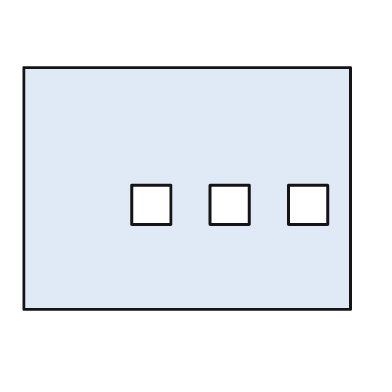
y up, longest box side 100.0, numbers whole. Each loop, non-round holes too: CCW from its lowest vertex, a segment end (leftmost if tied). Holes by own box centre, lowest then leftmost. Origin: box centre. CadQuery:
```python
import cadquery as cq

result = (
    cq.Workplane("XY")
    .moveTo(-50.0, -37.0)
    .lineTo(50.0, -37.0)
    .lineTo(50.0, 37.0)
    .lineTo(-50.0, 37.0)
    .close()
    .moveTo(-17.0, -11.0)
    .lineTo(-5.0, -11.0)
    .lineTo(-5.0, 1.0)
    .lineTo(-17.0, 1.0)
    .close()
    .moveTo(7.0, -11.0)
    .lineTo(19.0, -11.0)
    .lineTo(19.0, 1.0)
    .lineTo(7.0, 1.0)
    .close()
    .moveTo(31.0, -11.0)
    .lineTo(43.0, -11.0)
    .lineTo(43.0, 1.0)
    .lineTo(31.0, 1.0)
    .close()
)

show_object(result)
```